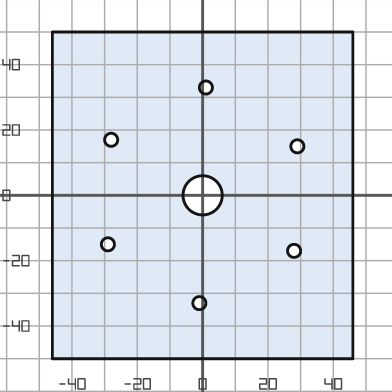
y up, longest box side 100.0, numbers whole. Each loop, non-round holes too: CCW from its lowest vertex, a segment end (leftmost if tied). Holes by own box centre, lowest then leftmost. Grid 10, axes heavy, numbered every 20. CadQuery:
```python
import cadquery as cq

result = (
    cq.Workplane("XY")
    .moveTo(-46.0, -50.0)
    .lineTo(46.0, -50.0)
    .lineTo(46.0, 50.0)
    .lineTo(-46.0, 50.0)
    .close()
    .moveTo(-1.0, -33.0)
    .circle(2.0)
    .moveTo(28.0, -17.0)
    .circle(2.0)
    .moveTo(-29.0, -15.0)
    .circle(2.0)
    .moveTo(0.0, 0.0)
    .circle(6.0)
    .moveTo(29.0, 15.0)
    .circle(2.0)
    .moveTo(-28.0, 17.0)
    .circle(2.0)
    .moveTo(1.0, 33.0)
    .circle(2.0)
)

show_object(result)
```